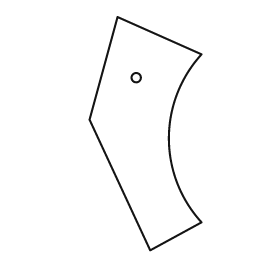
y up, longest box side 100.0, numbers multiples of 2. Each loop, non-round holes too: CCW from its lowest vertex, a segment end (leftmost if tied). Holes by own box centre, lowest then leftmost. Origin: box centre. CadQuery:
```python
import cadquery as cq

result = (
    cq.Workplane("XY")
    .moveTo(2.0, -50.0)
    .lineTo(24.0, -38.0)
    .threePointArc((10.0, -2.0), (24.0, 34.0))
    .lineTo(-12.0, 50.0)
    .lineTo(-24.0, 6.0)
    .close()
    .moveTo(-4.0, 24.0)
    .circle(2.0)
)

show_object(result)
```